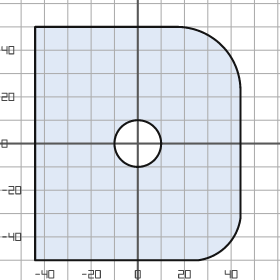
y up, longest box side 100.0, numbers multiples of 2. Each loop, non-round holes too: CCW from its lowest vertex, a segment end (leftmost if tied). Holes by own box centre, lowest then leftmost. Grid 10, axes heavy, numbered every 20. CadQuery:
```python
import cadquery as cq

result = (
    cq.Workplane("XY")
    .moveTo(-44.0, -50.0)
    .lineTo(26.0, -50.0)
    .threePointArc((38.0, -44.0), (44.0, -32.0))
    .lineTo(44.0, 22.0)
    .threePointArc((36.0, 42.0), (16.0, 50.0))
    .lineTo(-44.0, 50.0)
    .close()
    .moveTo(0.0, 0.0)
    .circle(10.0)
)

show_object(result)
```